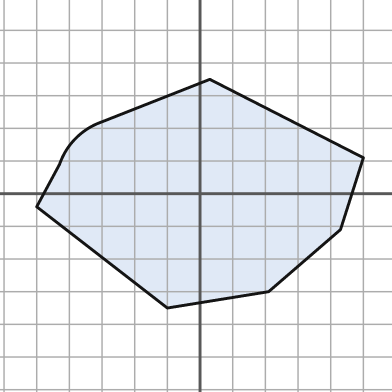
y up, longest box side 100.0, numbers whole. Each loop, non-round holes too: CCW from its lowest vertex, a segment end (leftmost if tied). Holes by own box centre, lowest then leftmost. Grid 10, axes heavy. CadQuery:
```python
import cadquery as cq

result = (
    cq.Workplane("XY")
    .moveTo(-10.0, -35.0)
    .lineTo(21.0, -30.0)
    .lineTo(43.0, -11.0)
    .lineTo(50.0, 11.0)
    .lineTo(3.0, 35.0)
    .lineTo(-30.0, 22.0)
    .threePointArc((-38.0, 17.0), (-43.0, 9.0))
    .lineTo(-50.0, -4.0)
    .close()
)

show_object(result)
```